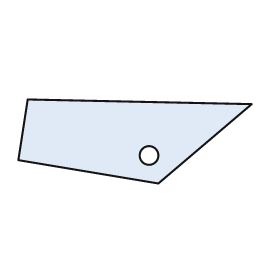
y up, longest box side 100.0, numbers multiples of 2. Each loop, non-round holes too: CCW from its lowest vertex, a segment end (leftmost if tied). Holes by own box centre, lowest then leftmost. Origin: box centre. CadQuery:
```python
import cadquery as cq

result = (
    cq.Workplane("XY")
    .moveTo(10.0, -18.0)
    .lineTo(50.0, 16.0)
    .lineTo(-46.0, 18.0)
    .lineTo(-50.0, -8.0)
    .close()
    .moveTo(6.0, -6.0)
    .circle(4.0)
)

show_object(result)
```